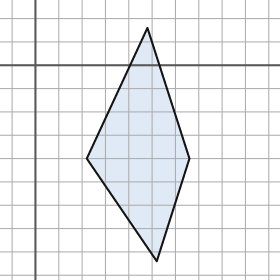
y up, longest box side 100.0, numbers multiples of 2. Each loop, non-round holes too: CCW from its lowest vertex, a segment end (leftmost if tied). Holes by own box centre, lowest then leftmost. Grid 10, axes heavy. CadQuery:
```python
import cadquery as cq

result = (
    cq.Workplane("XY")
    .moveTo(52.0, -84.0)
    .lineTo(66.0, -40.0)
    .lineTo(48.0, 16.0)
    .lineTo(22.0, -40.0)
    .close()
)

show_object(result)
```